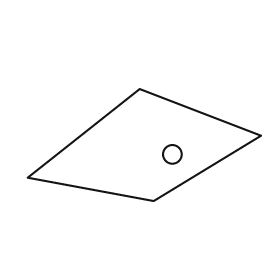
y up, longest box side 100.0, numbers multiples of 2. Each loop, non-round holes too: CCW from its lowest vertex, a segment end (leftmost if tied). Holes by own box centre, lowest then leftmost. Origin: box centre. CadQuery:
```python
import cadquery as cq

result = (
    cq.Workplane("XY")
    .moveTo(4.0, -24.0)
    .lineTo(50.0, 4.0)
    .lineTo(-2.0, 24.0)
    .lineTo(-50.0, -14.0)
    .close()
    .moveTo(12.0, -4.0)
    .circle(4.0)
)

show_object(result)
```